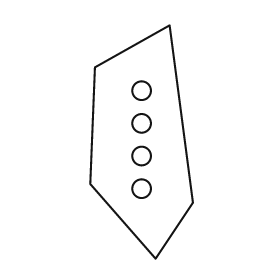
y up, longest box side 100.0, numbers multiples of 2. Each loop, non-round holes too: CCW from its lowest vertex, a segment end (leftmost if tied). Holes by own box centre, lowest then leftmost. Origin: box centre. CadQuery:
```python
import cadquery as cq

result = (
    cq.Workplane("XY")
    .moveTo(6.0, -50.0)
    .lineTo(22.0, -26.0)
    .lineTo(12.0, 50.0)
    .lineTo(-20.0, 32.0)
    .lineTo(-22.0, -18.0)
    .close()
    .moveTo(0.0, -20.0)
    .circle(4.0)
    .moveTo(0.0, -6.0)
    .circle(4.0)
    .moveTo(0.0, 8.0)
    .circle(4.0)
    .moveTo(0.0, 22.0)
    .circle(4.0)
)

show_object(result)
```